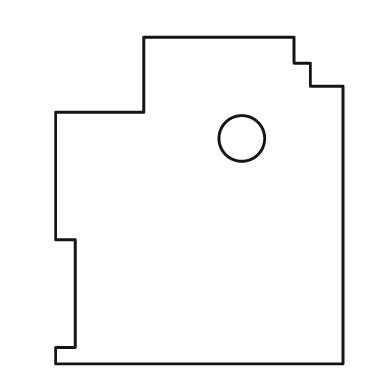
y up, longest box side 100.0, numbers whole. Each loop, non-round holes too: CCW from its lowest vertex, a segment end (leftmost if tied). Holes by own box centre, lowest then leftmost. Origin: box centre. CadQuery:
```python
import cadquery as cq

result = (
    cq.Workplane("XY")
    .moveTo(-44.0, -50.0)
    .lineTo(44.0, -50.0)
    .lineTo(44.0, 35.0)
    .lineTo(34.0, 35.0)
    .lineTo(34.0, 42.0)
    .lineTo(29.0, 42.0)
    .lineTo(29.0, 50.0)
    .lineTo(-17.0, 50.0)
    .lineTo(-17.0, 27.0)
    .lineTo(-44.0, 27.0)
    .lineTo(-44.0, -12.0)
    .lineTo(-38.0, -12.0)
    .lineTo(-38.0, -45.0)
    .lineTo(-44.0, -45.0)
    .close()
    .moveTo(13.0, 19.0)
    .circle(7.0)
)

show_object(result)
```